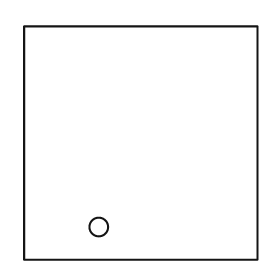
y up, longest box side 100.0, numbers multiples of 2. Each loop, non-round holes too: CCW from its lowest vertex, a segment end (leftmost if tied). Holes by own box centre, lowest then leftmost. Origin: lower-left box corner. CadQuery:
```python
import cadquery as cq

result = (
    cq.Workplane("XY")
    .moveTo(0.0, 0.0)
    .lineTo(100.0, 0.0)
    .lineTo(100.0, 100.0)
    .lineTo(0.0, 100.0)
    .close()
    .moveTo(32.0, 14.0)
    .circle(4.0)
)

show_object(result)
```